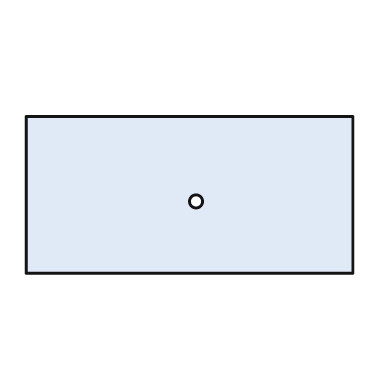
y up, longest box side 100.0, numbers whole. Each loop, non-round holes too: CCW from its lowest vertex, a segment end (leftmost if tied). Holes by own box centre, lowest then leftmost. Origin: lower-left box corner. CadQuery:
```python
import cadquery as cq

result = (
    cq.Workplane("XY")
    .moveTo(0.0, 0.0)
    .lineTo(100.0, 0.0)
    .lineTo(100.0, 48.0)
    .lineTo(0.0, 48.0)
    .close()
    .moveTo(52.0, 22.0)
    .circle(2.0)
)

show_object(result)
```